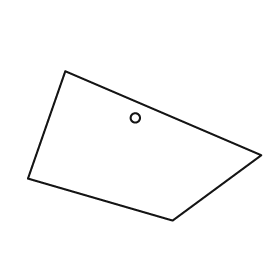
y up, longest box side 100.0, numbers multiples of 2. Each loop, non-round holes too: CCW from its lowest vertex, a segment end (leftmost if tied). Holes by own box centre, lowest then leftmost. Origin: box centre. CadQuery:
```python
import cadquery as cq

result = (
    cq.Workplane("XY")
    .moveTo(12.0, -32.0)
    .lineTo(50.0, -4.0)
    .lineTo(-34.0, 32.0)
    .lineTo(-50.0, -14.0)
    .close()
    .moveTo(-4.0, 12.0)
    .circle(2.0)
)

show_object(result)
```